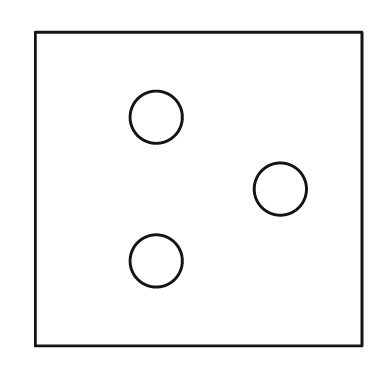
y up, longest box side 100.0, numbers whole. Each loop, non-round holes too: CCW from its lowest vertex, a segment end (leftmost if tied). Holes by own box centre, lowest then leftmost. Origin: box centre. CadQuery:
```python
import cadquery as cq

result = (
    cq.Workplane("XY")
    .moveTo(-50.0, -48.0)
    .lineTo(50.0, -48.0)
    .lineTo(50.0, 48.0)
    .lineTo(-50.0, 48.0)
    .close()
    .moveTo(-13.0, -22.0)
    .circle(8.0)
    .moveTo(25.0, 0.0)
    .circle(8.0)
    .moveTo(-13.0, 22.0)
    .circle(8.0)
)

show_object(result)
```